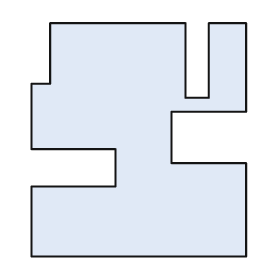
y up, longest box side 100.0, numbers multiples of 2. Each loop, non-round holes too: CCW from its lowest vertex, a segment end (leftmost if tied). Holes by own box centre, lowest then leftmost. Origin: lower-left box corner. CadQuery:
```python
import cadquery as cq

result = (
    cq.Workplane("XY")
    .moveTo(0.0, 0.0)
    .lineTo(92.0, 0.0)
    .lineTo(92.0, 40.0)
    .lineTo(60.0, 40.0)
    .lineTo(60.0, 62.0)
    .lineTo(92.0, 62.0)
    .lineTo(92.0, 100.0)
    .lineTo(76.0, 100.0)
    .lineTo(76.0, 68.0)
    .lineTo(66.0, 68.0)
    .lineTo(66.0, 100.0)
    .lineTo(8.0, 100.0)
    .lineTo(8.0, 74.0)
    .lineTo(0.0, 74.0)
    .lineTo(0.0, 46.0)
    .lineTo(36.0, 46.0)
    .lineTo(36.0, 30.0)
    .lineTo(0.0, 30.0)
    .close()
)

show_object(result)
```